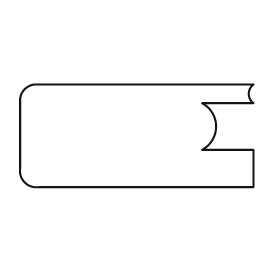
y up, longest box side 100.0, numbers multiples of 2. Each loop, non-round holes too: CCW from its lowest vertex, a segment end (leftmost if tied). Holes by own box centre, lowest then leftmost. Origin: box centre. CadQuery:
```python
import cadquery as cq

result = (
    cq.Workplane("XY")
    .moveTo(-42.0, -22.0)
    .lineTo(50.0, -22.0)
    .lineTo(50.0, -6.0)
    .lineTo(28.0, -6.0)
    .threePointArc((34.0, 4.0), (28.0, 14.0))
    .lineTo(50.0, 14.0)
    .threePointArc((48.0, 18.0), (50.0, 22.0))
    .lineTo(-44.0, 22.0)
    .threePointArc((-48.0, 20.0), (-50.0, 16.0))
    .lineTo(-50.0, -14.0)
    .threePointArc((-48.0, -20.0), (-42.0, -22.0))
    .close()
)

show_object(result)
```